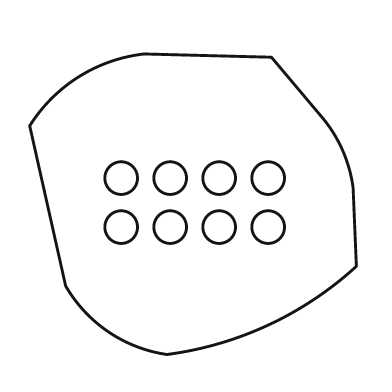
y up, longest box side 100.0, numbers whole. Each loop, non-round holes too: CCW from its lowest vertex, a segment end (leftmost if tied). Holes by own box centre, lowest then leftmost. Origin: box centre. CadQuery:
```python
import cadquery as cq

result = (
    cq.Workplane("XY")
    .moveTo(-8.0, -46.0)
    .threePointArc((23.0, -37.0), (50.0, -19.0))
    .lineTo(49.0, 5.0)
    .threePointArc((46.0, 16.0), (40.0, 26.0))
    .lineTo(24.0, 45.0)
    .lineTo(-15.0, 46.0)
    .threePointArc((-35.0, 39.0), (-50.0, 24.0))
    .lineTo(-39.0, -25.0)
    .threePointArc((-26.0, -39.0), (-8.0, -46.0))
    .close()
    .moveTo(-22.0, -7.0)
    .circle(5.0)
    .moveTo(-7.0, -7.0)
    .circle(5.0)
    .moveTo(8.0, -7.0)
    .circle(5.0)
    .moveTo(23.0, -7.0)
    .circle(5.0)
    .moveTo(-22.0, 8.0)
    .circle(5.0)
    .moveTo(-7.0, 8.0)
    .circle(5.0)
    .moveTo(8.0, 8.0)
    .circle(5.0)
    .moveTo(23.0, 8.0)
    .circle(5.0)
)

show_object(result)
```